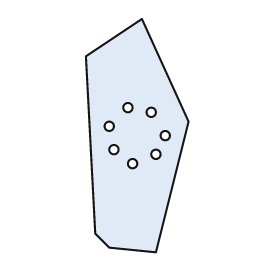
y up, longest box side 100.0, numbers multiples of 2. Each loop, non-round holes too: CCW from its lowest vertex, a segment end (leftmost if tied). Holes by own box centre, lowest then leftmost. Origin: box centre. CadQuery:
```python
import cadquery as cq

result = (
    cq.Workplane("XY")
    .moveTo(8.0, -50.0)
    .lineTo(22.0, 6.0)
    .lineTo(2.0, 50.0)
    .lineTo(-22.0, 34.0)
    .lineTo(-18.0, -42.0)
    .lineTo(-12.0, -48.0)
    .close()
    .moveTo(-2.0, -12.0)
    .circle(2.0)
    .moveTo(8.0, -8.0)
    .circle(2.0)
    .moveTo(-10.0, -6.0)
    .circle(2.0)
    .moveTo(12.0, 0.0)
    .circle(2.0)
    .moveTo(-12.0, 4.0)
    .circle(2.0)
    .moveTo(6.0, 10.0)
    .circle(2.0)
    .moveTo(-4.0, 12.0)
    .circle(2.0)
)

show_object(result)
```